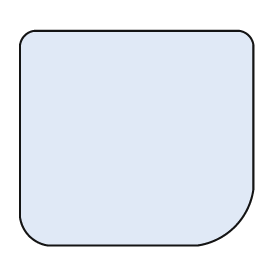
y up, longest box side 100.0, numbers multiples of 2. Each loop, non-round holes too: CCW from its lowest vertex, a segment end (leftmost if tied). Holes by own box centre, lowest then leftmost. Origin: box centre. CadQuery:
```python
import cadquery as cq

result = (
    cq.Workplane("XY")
    .moveTo(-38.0, -46.0)
    .lineTo(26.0, -46.0)
    .threePointArc((42.0, -38.0), (50.0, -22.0))
    .lineTo(50.0, 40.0)
    .threePointArc((48.0, 44.0), (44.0, 46.0))
    .lineTo(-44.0, 46.0)
    .threePointArc((-48.0, 44.0), (-50.0, 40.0))
    .lineTo(-50.0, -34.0)
    .threePointArc((-46.0, -42.0), (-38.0, -46.0))
    .close()
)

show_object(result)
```